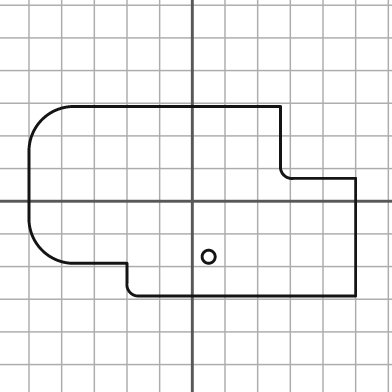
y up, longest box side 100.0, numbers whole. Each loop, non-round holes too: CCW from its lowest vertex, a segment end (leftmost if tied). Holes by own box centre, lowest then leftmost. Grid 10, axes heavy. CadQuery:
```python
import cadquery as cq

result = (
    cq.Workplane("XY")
    .moveTo(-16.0, -29.0)
    .lineTo(50.0, -29.0)
    .lineTo(50.0, 7.0)
    .lineTo(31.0, 7.0)
    .threePointArc((28.0, 8.0), (27.0, 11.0))
    .lineTo(27.0, 29.0)
    .lineTo(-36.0, 29.0)
    .threePointArc((-46.0, 25.0), (-50.0, 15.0))
    .lineTo(-50.0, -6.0)
    .threePointArc((-46.0, -15.0), (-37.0, -19.0))
    .lineTo(-20.0, -19.0)
    .lineTo(-20.0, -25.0)
    .threePointArc((-19.0, -28.0), (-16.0, -29.0))
    .close()
    .moveTo(5.0, -17.0)
    .circle(2.0)
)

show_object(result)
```